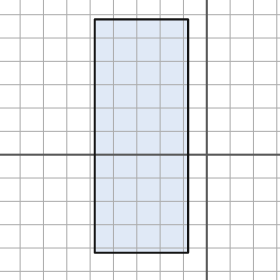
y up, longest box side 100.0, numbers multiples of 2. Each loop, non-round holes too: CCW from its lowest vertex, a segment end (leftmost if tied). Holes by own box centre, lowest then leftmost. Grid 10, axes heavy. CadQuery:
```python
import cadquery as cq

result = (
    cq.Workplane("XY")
    .moveTo(-48.0, -42.0)
    .lineTo(-8.0, -42.0)
    .lineTo(-8.0, 58.0)
    .lineTo(-48.0, 58.0)
    .close()
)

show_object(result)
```